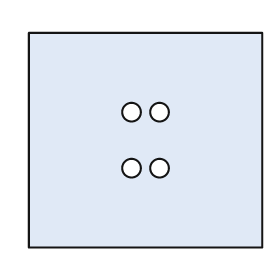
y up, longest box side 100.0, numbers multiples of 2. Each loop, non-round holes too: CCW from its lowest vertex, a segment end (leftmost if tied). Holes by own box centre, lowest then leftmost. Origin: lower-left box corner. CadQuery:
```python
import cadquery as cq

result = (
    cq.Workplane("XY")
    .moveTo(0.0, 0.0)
    .lineTo(100.0, 0.0)
    .lineTo(100.0, 92.0)
    .lineTo(0.0, 92.0)
    .close()
    .moveTo(44.0, 34.0)
    .circle(4.0)
    .moveTo(56.0, 34.0)
    .circle(4.0)
    .moveTo(44.0, 58.0)
    .circle(4.0)
    .moveTo(56.0, 58.0)
    .circle(4.0)
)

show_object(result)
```